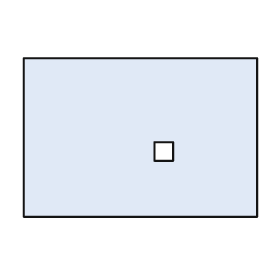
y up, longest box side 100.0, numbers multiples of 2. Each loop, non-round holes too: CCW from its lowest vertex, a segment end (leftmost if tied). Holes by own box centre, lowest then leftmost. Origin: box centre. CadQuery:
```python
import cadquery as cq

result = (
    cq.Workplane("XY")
    .moveTo(-50.0, -34.0)
    .lineTo(50.0, -34.0)
    .lineTo(50.0, 34.0)
    .lineTo(-50.0, 34.0)
    .close()
    .moveTo(6.0, -10.0)
    .lineTo(14.0, -10.0)
    .lineTo(14.0, -2.0)
    .lineTo(6.0, -2.0)
    .close()
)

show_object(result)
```